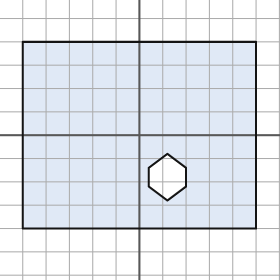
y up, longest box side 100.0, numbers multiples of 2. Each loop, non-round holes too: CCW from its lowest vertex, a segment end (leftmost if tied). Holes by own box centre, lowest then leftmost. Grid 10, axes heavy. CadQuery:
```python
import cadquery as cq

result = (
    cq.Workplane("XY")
    .moveTo(-50.0, -40.0)
    .lineTo(50.0, -40.0)
    .lineTo(50.0, 40.0)
    .lineTo(-50.0, 40.0)
    .close()
    .moveTo(12.0, -28.0)
    .lineTo(20.0, -22.0)
    .lineTo(20.0, -14.0)
    .lineTo(12.0, -8.0)
    .lineTo(4.0, -14.0)
    .lineTo(4.0, -22.0)
    .close()
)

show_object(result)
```